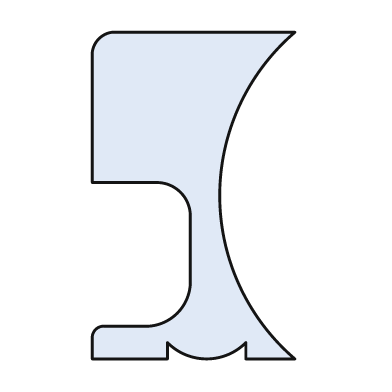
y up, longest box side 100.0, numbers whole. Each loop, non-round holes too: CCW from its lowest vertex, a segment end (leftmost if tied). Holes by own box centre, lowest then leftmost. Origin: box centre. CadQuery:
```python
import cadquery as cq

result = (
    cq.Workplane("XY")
    .moveTo(-31.0, -50.0)
    .lineTo(-8.0, -50.0)
    .lineTo(-8.0, -45.0)
    .threePointArc((4.0, -50.0), (16.0, -45.0))
    .lineTo(16.0, -50.0)
    .lineTo(31.0, -50.0)
    .threePointArc((8.0, 0.0), (31.0, 50.0))
    .lineTo(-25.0, 50.0)
    .threePointArc((-29.0, 48.0), (-31.0, 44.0))
    .lineTo(-31.0, 4.0)
    .lineTo(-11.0, 4.0)
    .threePointArc((-4.0, 1.0), (-1.0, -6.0))
    .lineTo(-1.0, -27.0)
    .threePointArc((-5.0, -36.0), (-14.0, -40.0))
    .lineTo(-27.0, -40.0)
    .threePointArc((-30.0, -41.0), (-31.0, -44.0))
    .close()
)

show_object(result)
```